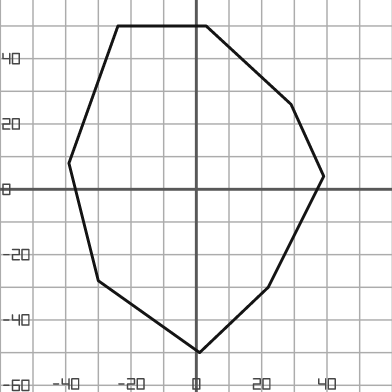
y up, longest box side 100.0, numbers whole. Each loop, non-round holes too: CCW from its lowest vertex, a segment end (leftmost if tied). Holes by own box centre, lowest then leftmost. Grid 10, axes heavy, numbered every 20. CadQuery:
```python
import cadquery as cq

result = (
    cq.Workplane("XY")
    .moveTo(1.0, -50.0)
    .lineTo(22.0, -30.0)
    .lineTo(39.0, 4.0)
    .lineTo(29.0, 26.0)
    .lineTo(3.0, 50.0)
    .lineTo(-24.0, 50.0)
    .lineTo(-39.0, 8.0)
    .lineTo(-30.0, -28.0)
    .close()
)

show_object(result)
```